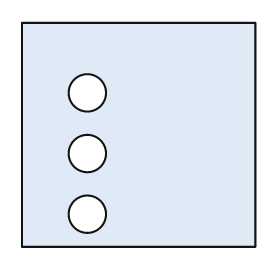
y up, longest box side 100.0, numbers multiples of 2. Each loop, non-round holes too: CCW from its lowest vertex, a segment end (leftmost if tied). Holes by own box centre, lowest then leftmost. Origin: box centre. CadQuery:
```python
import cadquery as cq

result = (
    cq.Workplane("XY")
    .moveTo(-50.0, -48.0)
    .lineTo(50.0, -48.0)
    .lineTo(50.0, 48.0)
    .lineTo(-50.0, 48.0)
    .close()
    .moveTo(-22.0, -34.0)
    .circle(8.0)
    .moveTo(-22.0, -8.0)
    .circle(8.0)
    .moveTo(-22.0, 18.0)
    .circle(8.0)
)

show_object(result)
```